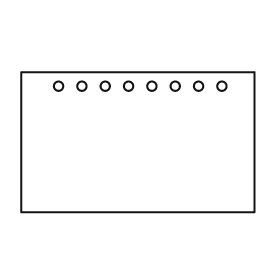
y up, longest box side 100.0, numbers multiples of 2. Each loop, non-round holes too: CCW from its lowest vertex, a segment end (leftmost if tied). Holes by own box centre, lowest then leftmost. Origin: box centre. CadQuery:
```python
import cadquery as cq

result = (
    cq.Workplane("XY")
    .moveTo(-50.0, -30.0)
    .lineTo(50.0, -30.0)
    .lineTo(50.0, 30.0)
    .lineTo(-50.0, 30.0)
    .close()
    .moveTo(-34.0, 24.0)
    .circle(2.0)
    .moveTo(-24.0, 24.0)
    .circle(2.0)
    .moveTo(-14.0, 24.0)
    .circle(2.0)
    .moveTo(-4.0, 24.0)
    .circle(2.0)
    .moveTo(6.0, 24.0)
    .circle(2.0)
    .moveTo(16.0, 24.0)
    .circle(2.0)
    .moveTo(26.0, 24.0)
    .circle(2.0)
    .moveTo(36.0, 24.0)
    .circle(2.0)
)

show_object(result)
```